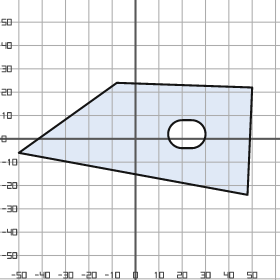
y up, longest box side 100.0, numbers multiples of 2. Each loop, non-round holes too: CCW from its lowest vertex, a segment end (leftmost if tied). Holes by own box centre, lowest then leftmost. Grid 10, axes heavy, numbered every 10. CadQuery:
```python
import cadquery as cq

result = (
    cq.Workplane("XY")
    .moveTo(48.0, -24.0)
    .lineTo(50.0, 22.0)
    .lineTo(-8.0, 24.0)
    .lineTo(-50.0, -6.0)
    .close()
    .moveTo(20.0, -4.0)
    .lineTo(24.0, -4.0)
    .threePointArc((30.0, 2.0), (24.0, 8.0))
    .lineTo(20.0, 8.0)
    .threePointArc((14.0, 2.0), (20.0, -4.0))
    .close()
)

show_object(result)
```